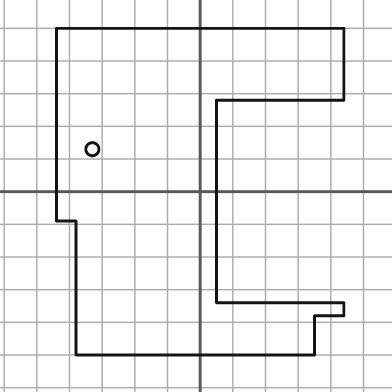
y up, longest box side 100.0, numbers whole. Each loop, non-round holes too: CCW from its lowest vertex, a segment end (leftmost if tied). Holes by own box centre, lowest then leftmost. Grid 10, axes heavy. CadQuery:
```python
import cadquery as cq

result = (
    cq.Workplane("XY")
    .moveTo(-38.0, -50.0)
    .lineTo(35.0, -50.0)
    .lineTo(35.0, -38.0)
    .lineTo(44.0, -38.0)
    .lineTo(44.0, -34.0)
    .lineTo(5.0, -34.0)
    .lineTo(5.0, 28.0)
    .lineTo(44.0, 28.0)
    .lineTo(44.0, 50.0)
    .lineTo(-44.0, 50.0)
    .lineTo(-44.0, -9.0)
    .lineTo(-38.0, -9.0)
    .close()
    .moveTo(-33.0, 13.0)
    .circle(2.0)
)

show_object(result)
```